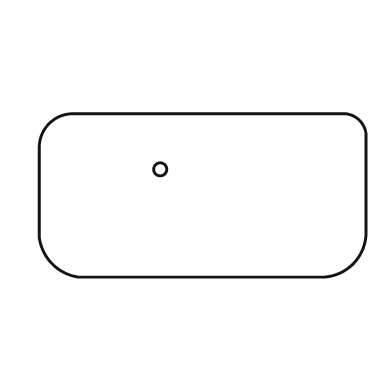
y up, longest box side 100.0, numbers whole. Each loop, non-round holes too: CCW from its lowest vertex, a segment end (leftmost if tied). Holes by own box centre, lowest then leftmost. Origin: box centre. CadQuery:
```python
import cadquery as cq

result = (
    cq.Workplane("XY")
    .moveTo(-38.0, -25.0)
    .lineTo(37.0, -25.0)
    .threePointArc((46.0, -21.0), (50.0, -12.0))
    .lineTo(50.0, 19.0)
    .threePointArc((48.0, 23.0), (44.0, 25.0))
    .lineTo(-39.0, 25.0)
    .threePointArc((-47.0, 22.0), (-50.0, 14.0))
    .lineTo(-50.0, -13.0)
    .threePointArc((-46.0, -21.0), (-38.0, -25.0))
    .close()
    .moveTo(-13.0, 8.0)
    .circle(2.0)
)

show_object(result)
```